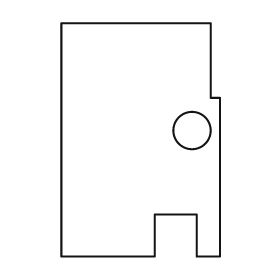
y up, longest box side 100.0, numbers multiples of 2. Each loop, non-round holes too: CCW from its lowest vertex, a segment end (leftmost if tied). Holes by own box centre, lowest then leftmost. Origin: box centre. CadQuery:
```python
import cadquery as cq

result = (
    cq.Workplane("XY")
    .moveTo(-34.0, -50.0)
    .lineTo(6.0, -50.0)
    .lineTo(6.0, -32.0)
    .lineTo(24.0, -32.0)
    .lineTo(24.0, -50.0)
    .lineTo(34.0, -50.0)
    .lineTo(34.0, 18.0)
    .lineTo(30.0, 18.0)
    .lineTo(30.0, 50.0)
    .lineTo(-34.0, 50.0)
    .close()
    .moveTo(22.0, 4.0)
    .circle(8.0)
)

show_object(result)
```